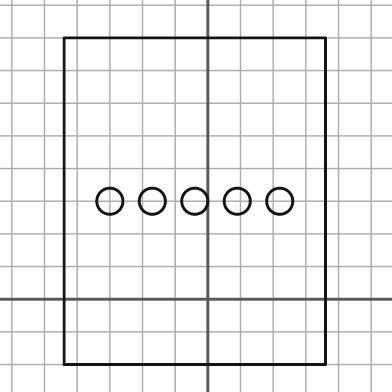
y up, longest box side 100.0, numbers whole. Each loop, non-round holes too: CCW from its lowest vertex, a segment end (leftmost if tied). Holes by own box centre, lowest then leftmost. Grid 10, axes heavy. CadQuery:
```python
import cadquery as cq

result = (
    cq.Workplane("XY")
    .moveTo(-44.0, -20.0)
    .lineTo(36.0, -20.0)
    .lineTo(36.0, 80.0)
    .lineTo(-44.0, 80.0)
    .close()
    .moveTo(-30.0, 30.0)
    .circle(4.0)
    .moveTo(-17.0, 30.0)
    .circle(4.0)
    .moveTo(-4.0, 30.0)
    .circle(4.0)
    .moveTo(9.0, 30.0)
    .circle(4.0)
    .moveTo(22.0, 30.0)
    .circle(4.0)
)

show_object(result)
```